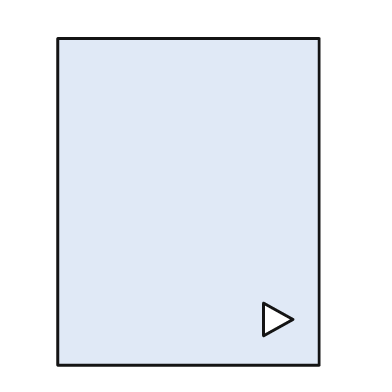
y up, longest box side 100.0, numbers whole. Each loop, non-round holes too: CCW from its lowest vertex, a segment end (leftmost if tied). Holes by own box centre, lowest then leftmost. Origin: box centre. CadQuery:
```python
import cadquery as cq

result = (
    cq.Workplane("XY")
    .moveTo(-40.0, -50.0)
    .lineTo(40.0, -50.0)
    .lineTo(40.0, 50.0)
    .lineTo(-40.0, 50.0)
    .close()
    .moveTo(23.0, -41.0)
    .lineTo(32.0, -36.0)
    .lineTo(23.0, -31.0)
    .close()
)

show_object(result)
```